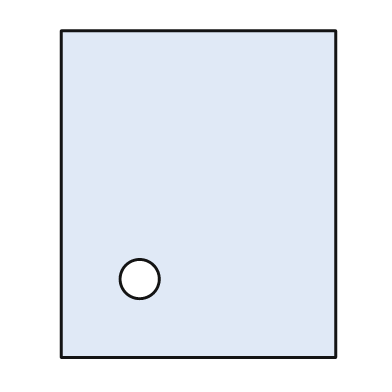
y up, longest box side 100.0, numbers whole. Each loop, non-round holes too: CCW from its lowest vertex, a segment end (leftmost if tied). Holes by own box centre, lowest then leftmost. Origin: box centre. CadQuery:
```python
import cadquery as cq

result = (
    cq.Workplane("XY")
    .moveTo(-42.0, -50.0)
    .lineTo(42.0, -50.0)
    .lineTo(42.0, 50.0)
    .lineTo(-42.0, 50.0)
    .close()
    .moveTo(-18.0, -26.0)
    .circle(6.0)
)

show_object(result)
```